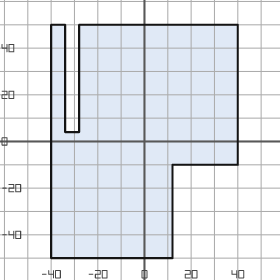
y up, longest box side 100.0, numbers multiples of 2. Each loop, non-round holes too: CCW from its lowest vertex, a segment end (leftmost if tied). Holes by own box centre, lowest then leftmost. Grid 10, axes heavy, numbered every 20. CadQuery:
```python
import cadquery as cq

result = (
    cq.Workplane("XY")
    .moveTo(-40.0, -50.0)
    .lineTo(12.0, -50.0)
    .lineTo(12.0, -10.0)
    .lineTo(40.0, -10.0)
    .lineTo(40.0, 50.0)
    .lineTo(-28.0, 50.0)
    .lineTo(-28.0, 4.0)
    .lineTo(-34.0, 4.0)
    .lineTo(-34.0, 50.0)
    .lineTo(-40.0, 50.0)
    .close()
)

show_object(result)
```